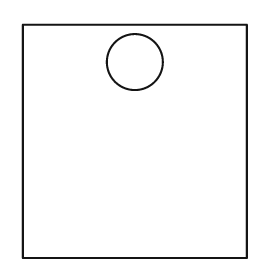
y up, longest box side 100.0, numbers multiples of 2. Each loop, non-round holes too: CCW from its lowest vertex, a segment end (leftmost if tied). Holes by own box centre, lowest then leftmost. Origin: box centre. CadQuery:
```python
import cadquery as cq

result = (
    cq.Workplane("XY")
    .moveTo(-48.0, -50.0)
    .lineTo(48.0, -50.0)
    .lineTo(48.0, 50.0)
    .lineTo(-48.0, 50.0)
    .close()
    .moveTo(0.0, 34.0)
    .circle(12.0)
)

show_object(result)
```